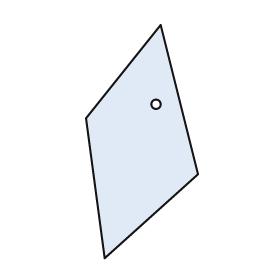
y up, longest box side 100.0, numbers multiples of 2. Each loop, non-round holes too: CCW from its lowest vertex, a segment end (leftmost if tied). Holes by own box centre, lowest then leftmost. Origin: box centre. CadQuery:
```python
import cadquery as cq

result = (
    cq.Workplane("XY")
    .moveTo(-16.0, -50.0)
    .lineTo(24.0, -14.0)
    .lineTo(8.0, 50.0)
    .lineTo(-24.0, 10.0)
    .close()
    .moveTo(6.0, 16.0)
    .circle(2.0)
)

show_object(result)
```